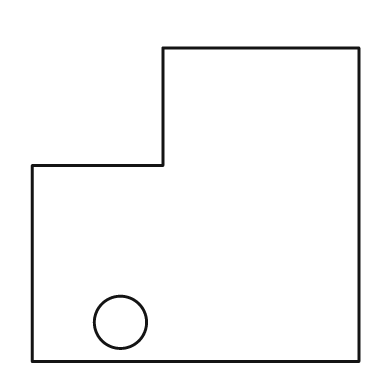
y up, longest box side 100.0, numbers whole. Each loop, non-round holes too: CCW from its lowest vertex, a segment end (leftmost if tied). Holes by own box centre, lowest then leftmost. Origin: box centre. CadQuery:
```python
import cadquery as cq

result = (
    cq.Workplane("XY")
    .moveTo(-50.0, -48.0)
    .lineTo(50.0, -48.0)
    .lineTo(50.0, 48.0)
    .lineTo(-10.0, 48.0)
    .lineTo(-10.0, 12.0)
    .lineTo(-50.0, 12.0)
    .close()
    .moveTo(-23.0, -36.0)
    .circle(8.0)
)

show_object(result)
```